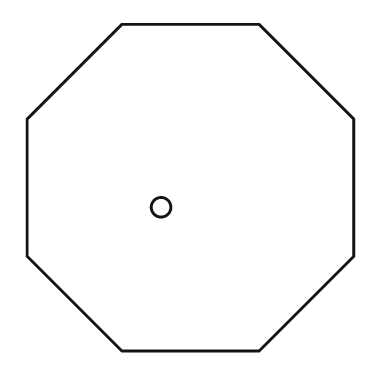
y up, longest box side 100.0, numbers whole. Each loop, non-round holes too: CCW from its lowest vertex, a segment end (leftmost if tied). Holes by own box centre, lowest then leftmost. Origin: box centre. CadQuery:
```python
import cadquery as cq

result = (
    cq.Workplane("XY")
    .moveTo(-21.0, -50.0)
    .lineTo(21.0, -50.0)
    .lineTo(50.0, -21.0)
    .lineTo(50.0, 21.0)
    .lineTo(21.0, 50.0)
    .lineTo(-21.0, 50.0)
    .lineTo(-50.0, 21.0)
    .lineTo(-50.0, -21.0)
    .close()
    .moveTo(-9.0, -6.0)
    .circle(3.0)
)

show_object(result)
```